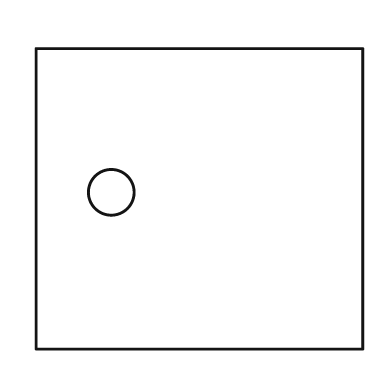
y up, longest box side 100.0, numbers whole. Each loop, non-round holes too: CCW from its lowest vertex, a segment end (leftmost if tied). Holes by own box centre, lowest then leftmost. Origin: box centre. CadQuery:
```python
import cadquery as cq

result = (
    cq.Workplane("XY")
    .moveTo(-50.0, -46.0)
    .lineTo(50.0, -46.0)
    .lineTo(50.0, 46.0)
    .lineTo(-50.0, 46.0)
    .close()
    .moveTo(-27.0, 2.0)
    .circle(7.0)
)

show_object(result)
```